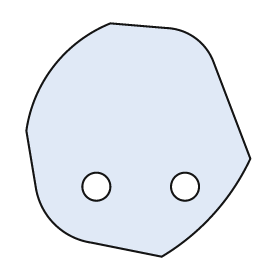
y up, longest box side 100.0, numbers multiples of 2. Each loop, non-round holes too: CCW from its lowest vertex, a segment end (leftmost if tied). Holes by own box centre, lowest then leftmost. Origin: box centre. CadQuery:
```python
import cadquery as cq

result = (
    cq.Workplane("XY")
    .moveTo(10.0, -50.0)
    .threePointArc((32.0, -32.0), (48.0, -8.0))
    .lineTo(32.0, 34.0)
    .threePointArc((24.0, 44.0), (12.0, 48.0))
    .lineTo(-12.0, 50.0)
    .threePointArc((-36.0, 32.0), (-48.0, 4.0))
    .lineTo(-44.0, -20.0)
    .threePointArc((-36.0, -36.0), (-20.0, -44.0))
    .close()
    .moveTo(-18.0, -20.0)
    .circle(6.0)
    .moveTo(20.0, -20.0)
    .circle(6.0)
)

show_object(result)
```